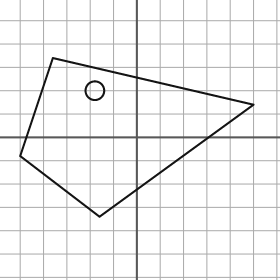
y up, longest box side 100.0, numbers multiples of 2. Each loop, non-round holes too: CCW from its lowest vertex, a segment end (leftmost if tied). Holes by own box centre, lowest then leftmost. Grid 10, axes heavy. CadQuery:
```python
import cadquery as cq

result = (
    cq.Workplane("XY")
    .moveTo(-16.0, -34.0)
    .lineTo(50.0, 14.0)
    .lineTo(-36.0, 34.0)
    .lineTo(-50.0, -8.0)
    .close()
    .moveTo(-18.0, 20.0)
    .circle(4.0)
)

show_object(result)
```